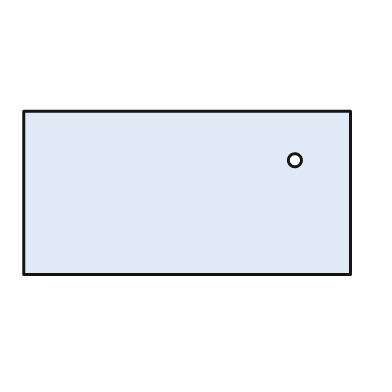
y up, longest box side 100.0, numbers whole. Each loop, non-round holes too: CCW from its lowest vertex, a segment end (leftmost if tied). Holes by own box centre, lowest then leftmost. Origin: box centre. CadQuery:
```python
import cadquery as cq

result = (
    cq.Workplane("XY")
    .moveTo(-50.0, -25.0)
    .lineTo(50.0, -25.0)
    .lineTo(50.0, 25.0)
    .lineTo(-50.0, 25.0)
    .close()
    .moveTo(33.0, 10.0)
    .circle(2.0)
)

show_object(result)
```